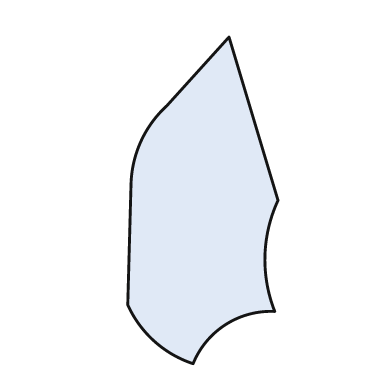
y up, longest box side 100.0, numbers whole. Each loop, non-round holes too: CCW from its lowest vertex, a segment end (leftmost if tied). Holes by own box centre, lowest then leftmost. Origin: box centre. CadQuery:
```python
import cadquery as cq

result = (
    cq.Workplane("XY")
    .moveTo(-3.0, -50.0)
    .threePointArc((7.0, -38.0), (22.0, -34.0))
    .threePointArc((19.0, -17.0), (23.0, 0.0))
    .lineTo(8.0, 50.0)
    .lineTo(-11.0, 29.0)
    .threePointArc((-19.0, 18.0), (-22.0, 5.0))
    .lineTo(-23.0, -32.0)
    .threePointArc((-15.0, -43.0), (-3.0, -50.0))
    .close()
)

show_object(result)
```